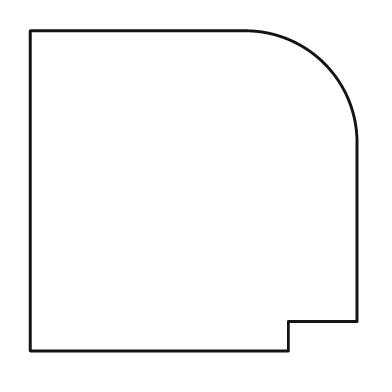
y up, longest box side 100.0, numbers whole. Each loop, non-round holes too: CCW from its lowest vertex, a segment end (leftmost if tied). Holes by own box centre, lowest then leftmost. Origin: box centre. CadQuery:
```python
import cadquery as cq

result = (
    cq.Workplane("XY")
    .moveTo(-50.0, -49.0)
    .lineTo(29.0, -49.0)
    .lineTo(29.0, -40.0)
    .lineTo(50.0, -40.0)
    .lineTo(50.0, 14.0)
    .threePointArc((40.0, 39.0), (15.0, 49.0))
    .lineTo(-50.0, 49.0)
    .close()
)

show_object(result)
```